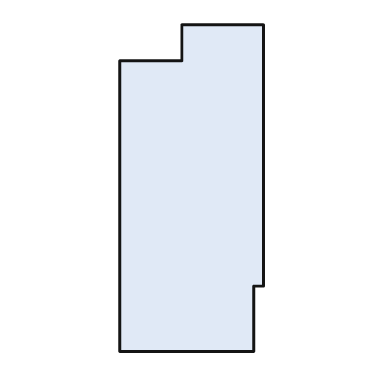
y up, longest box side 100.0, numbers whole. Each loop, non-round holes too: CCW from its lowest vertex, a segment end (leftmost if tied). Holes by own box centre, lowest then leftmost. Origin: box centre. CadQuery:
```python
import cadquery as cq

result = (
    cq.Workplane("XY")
    .moveTo(-22.0, -50.0)
    .lineTo(19.0, -50.0)
    .lineTo(19.0, -30.0)
    .lineTo(22.0, -30.0)
    .lineTo(22.0, 50.0)
    .lineTo(-3.0, 50.0)
    .lineTo(-3.0, 39.0)
    .lineTo(-22.0, 39.0)
    .close()
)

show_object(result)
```